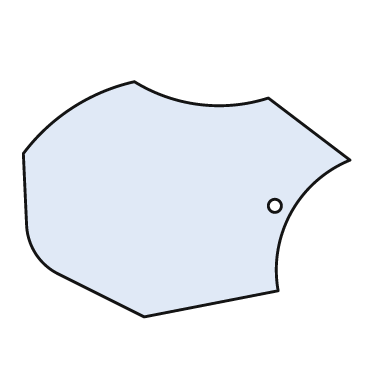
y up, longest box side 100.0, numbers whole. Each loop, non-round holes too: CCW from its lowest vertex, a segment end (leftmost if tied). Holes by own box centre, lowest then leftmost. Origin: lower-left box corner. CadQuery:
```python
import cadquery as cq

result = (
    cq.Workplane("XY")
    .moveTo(37.0, 0.0)
    .lineTo(78.0, 8.0)
    .threePointArc((82.0, 32.0), (100.0, 48.0))
    .lineTo(75.0, 67.0)
    .threePointArc((54.0, 65.0), (34.0, 72.0))
    .threePointArc((15.0, 64.0), (0.0, 50.0))
    .lineTo(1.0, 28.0)
    .threePointArc((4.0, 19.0), (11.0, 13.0))
    .close()
    .moveTo(77.0, 34.0)
    .circle(2.0)
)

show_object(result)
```